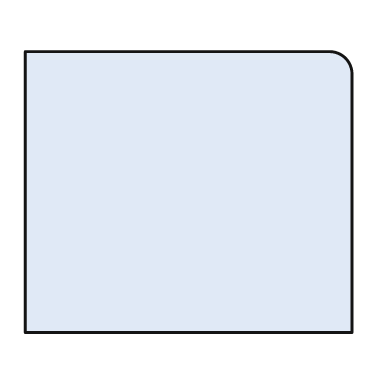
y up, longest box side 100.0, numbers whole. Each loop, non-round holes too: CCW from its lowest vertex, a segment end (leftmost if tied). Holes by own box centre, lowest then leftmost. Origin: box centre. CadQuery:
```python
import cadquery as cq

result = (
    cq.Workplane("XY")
    .moveTo(-50.0, -43.0)
    .lineTo(50.0, -43.0)
    .lineTo(50.0, 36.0)
    .threePointArc((48.0, 41.0), (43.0, 43.0))
    .lineTo(-50.0, 43.0)
    .close()
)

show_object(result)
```